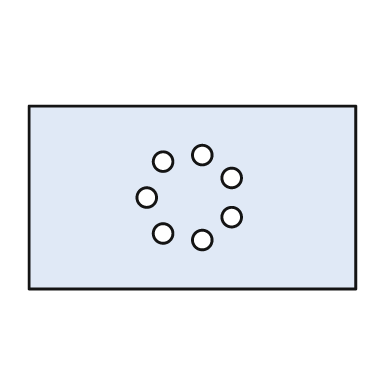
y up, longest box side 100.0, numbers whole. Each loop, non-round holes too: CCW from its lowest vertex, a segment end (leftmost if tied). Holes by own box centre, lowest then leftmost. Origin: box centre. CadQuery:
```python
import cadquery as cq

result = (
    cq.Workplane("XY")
    .moveTo(-50.0, -28.0)
    .lineTo(50.0, -28.0)
    .lineTo(50.0, 28.0)
    .lineTo(-50.0, 28.0)
    .close()
    .moveTo(3.0, -13.0)
    .circle(3.0)
    .moveTo(-9.0, -11.0)
    .circle(3.0)
    .moveTo(12.0, -6.0)
    .circle(3.0)
    .moveTo(-14.0, 0.0)
    .circle(3.0)
    .moveTo(12.0, 6.0)
    .circle(3.0)
    .moveTo(-9.0, 11.0)
    .circle(3.0)
    .moveTo(3.0, 13.0)
    .circle(3.0)
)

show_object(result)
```